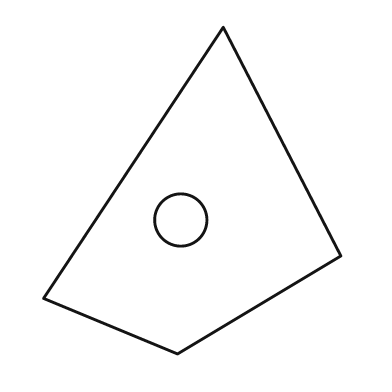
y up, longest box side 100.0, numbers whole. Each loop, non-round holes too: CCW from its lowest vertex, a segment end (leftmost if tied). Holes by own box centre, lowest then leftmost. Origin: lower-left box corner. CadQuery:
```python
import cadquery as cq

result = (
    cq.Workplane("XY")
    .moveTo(41.0, 0.0)
    .lineTo(91.0, 30.0)
    .lineTo(55.0, 100.0)
    .lineTo(0.0, 17.0)
    .close()
    .moveTo(42.0, 41.0)
    .circle(8.0)
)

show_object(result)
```